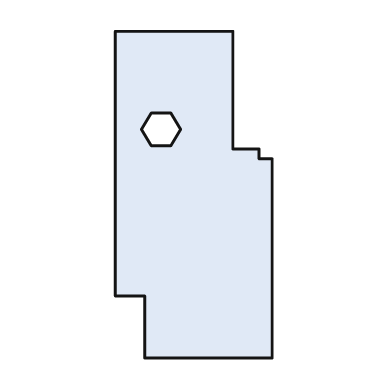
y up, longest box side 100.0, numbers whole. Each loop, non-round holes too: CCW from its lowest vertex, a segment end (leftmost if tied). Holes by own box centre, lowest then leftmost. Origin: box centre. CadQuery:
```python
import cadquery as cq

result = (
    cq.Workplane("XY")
    .moveTo(-15.0, -50.0)
    .lineTo(24.0, -50.0)
    .lineTo(24.0, 11.0)
    .lineTo(20.0, 11.0)
    .lineTo(20.0, 14.0)
    .lineTo(12.0, 14.0)
    .lineTo(12.0, 50.0)
    .lineTo(-24.0, 50.0)
    .lineTo(-24.0, -31.0)
    .lineTo(-15.0, -31.0)
    .close()
    .moveTo(-13.0, 15.0)
    .lineTo(-7.0, 15.0)
    .lineTo(-4.0, 20.0)
    .lineTo(-7.0, 25.0)
    .lineTo(-13.0, 25.0)
    .lineTo(-16.0, 20.0)
    .close()
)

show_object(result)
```